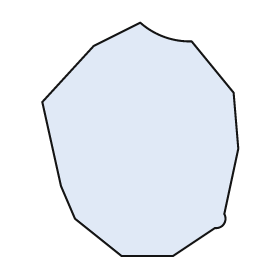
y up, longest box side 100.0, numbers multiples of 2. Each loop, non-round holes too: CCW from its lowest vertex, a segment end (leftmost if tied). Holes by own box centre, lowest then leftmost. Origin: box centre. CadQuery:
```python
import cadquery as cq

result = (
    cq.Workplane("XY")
    .moveTo(-8.0, -50.0)
    .lineTo(14.0, -50.0)
    .lineTo(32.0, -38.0)
    .threePointArc((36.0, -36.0), (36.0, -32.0))
    .lineTo(42.0, -4.0)
    .lineTo(40.0, 20.0)
    .lineTo(22.0, 42.0)
    .threePointArc((10.0, 44.0), (0.0, 50.0))
    .lineTo(-20.0, 40.0)
    .lineTo(-42.0, 16.0)
    .lineTo(-34.0, -20.0)
    .lineTo(-28.0, -34.0)
    .close()
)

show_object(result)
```